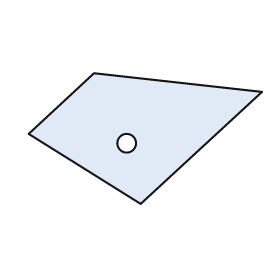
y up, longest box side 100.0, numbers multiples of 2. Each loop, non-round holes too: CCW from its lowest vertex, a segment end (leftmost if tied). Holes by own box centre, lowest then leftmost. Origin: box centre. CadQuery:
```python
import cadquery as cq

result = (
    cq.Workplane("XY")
    .moveTo(-2.0, -28.0)
    .lineTo(50.0, 20.0)
    .lineTo(-22.0, 28.0)
    .lineTo(-50.0, 2.0)
    .close()
    .moveTo(-8.0, -2.0)
    .circle(4.0)
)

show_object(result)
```